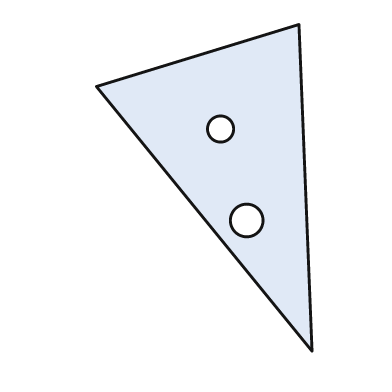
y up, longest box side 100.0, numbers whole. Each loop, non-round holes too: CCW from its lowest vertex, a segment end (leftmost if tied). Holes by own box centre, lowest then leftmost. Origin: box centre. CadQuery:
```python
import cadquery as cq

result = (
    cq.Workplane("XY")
    .moveTo(33.0, -50.0)
    .lineTo(29.0, 50.0)
    .lineTo(-33.0, 31.0)
    .close()
    .moveTo(13.0, -10.0)
    .circle(5.0)
    .moveTo(5.0, 18.0)
    .circle(4.0)
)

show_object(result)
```